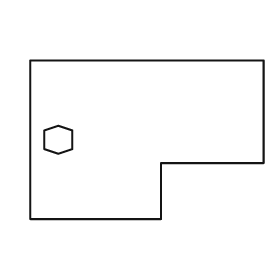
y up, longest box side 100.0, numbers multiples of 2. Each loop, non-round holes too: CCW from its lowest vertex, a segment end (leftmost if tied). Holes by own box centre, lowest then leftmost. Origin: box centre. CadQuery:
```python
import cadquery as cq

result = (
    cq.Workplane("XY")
    .moveTo(-50.0, -34.0)
    .lineTo(6.0, -34.0)
    .lineTo(6.0, -10.0)
    .lineTo(50.0, -10.0)
    .lineTo(50.0, 34.0)
    .lineTo(-50.0, 34.0)
    .close()
    .moveTo(-38.0, -6.0)
    .lineTo(-32.0, -4.0)
    .lineTo(-32.0, 4.0)
    .lineTo(-38.0, 6.0)
    .lineTo(-44.0, 4.0)
    .lineTo(-44.0, -4.0)
    .close()
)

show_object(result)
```